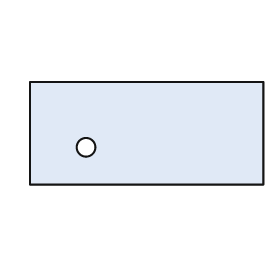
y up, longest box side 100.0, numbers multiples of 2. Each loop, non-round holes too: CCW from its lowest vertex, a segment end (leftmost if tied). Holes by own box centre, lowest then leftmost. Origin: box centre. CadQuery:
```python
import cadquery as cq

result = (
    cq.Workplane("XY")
    .moveTo(-50.0, -22.0)
    .lineTo(50.0, -22.0)
    .lineTo(50.0, 22.0)
    .lineTo(-50.0, 22.0)
    .close()
    .moveTo(-26.0, -6.0)
    .circle(4.0)
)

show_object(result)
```